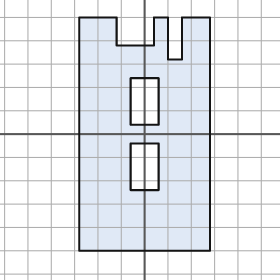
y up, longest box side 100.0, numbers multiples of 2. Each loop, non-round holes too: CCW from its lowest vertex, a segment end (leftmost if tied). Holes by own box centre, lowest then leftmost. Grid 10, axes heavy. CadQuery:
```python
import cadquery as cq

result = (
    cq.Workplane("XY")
    .moveTo(-28.0, -50.0)
    .lineTo(28.0, -50.0)
    .lineTo(28.0, 50.0)
    .lineTo(16.0, 50.0)
    .lineTo(16.0, 32.0)
    .lineTo(10.0, 32.0)
    .lineTo(10.0, 50.0)
    .lineTo(4.0, 50.0)
    .lineTo(4.0, 38.0)
    .lineTo(-12.0, 38.0)
    .lineTo(-12.0, 50.0)
    .lineTo(-28.0, 50.0)
    .close()
    .moveTo(-6.0, -24.0)
    .lineTo(6.0, -24.0)
    .lineTo(6.0, -4.0)
    .lineTo(-6.0, -4.0)
    .close()
    .moveTo(-6.0, 4.0)
    .lineTo(6.0, 4.0)
    .lineTo(6.0, 24.0)
    .lineTo(-6.0, 24.0)
    .close()
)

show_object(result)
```